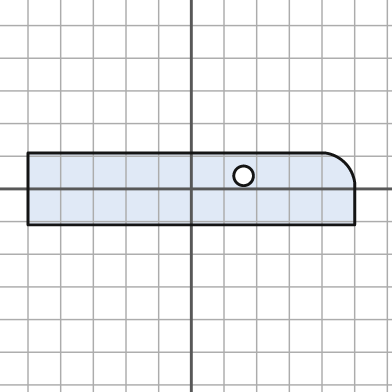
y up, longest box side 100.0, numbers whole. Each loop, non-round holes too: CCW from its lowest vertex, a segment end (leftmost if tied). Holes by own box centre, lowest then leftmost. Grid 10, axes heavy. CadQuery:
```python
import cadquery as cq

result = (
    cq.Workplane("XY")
    .moveTo(-50.0, -11.0)
    .lineTo(50.0, -11.0)
    .lineTo(50.0, 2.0)
    .threePointArc((47.0, 8.0), (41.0, 11.0))
    .lineTo(-50.0, 11.0)
    .close()
    .moveTo(16.0, 4.0)
    .circle(3.0)
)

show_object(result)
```